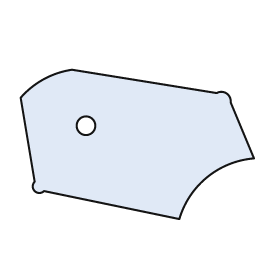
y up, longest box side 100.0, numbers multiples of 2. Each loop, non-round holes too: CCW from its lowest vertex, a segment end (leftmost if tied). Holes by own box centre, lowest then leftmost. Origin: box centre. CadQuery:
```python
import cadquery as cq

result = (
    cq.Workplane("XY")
    .moveTo(18.0, -32.0)
    .threePointArc((30.0, -14.0), (50.0, -6.0))
    .lineTo(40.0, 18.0)
    .threePointArc((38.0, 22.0), (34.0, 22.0))
    .lineTo(-28.0, 32.0)
    .threePointArc((-40.0, 28.0), (-50.0, 20.0))
    .lineTo(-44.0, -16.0)
    .threePointArc((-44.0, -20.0), (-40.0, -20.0))
    .close()
    .moveTo(-22.0, 8.0)
    .circle(4.0)
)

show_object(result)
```